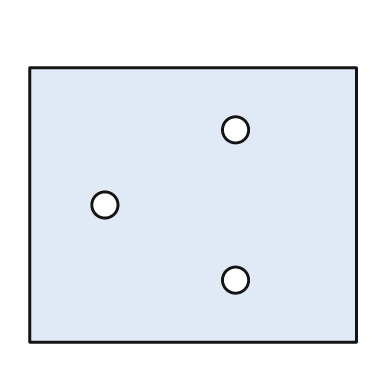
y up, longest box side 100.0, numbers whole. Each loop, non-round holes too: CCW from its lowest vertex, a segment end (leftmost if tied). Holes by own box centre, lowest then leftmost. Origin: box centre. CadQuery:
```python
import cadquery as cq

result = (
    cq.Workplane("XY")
    .moveTo(-50.0, -42.0)
    .lineTo(50.0, -42.0)
    .lineTo(50.0, 42.0)
    .lineTo(-50.0, 42.0)
    .close()
    .moveTo(13.0, -23.0)
    .circle(4.0)
    .moveTo(-27.0, 0.0)
    .circle(4.0)
    .moveTo(13.0, 23.0)
    .circle(4.0)
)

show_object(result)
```